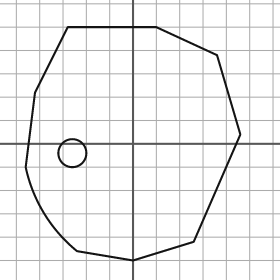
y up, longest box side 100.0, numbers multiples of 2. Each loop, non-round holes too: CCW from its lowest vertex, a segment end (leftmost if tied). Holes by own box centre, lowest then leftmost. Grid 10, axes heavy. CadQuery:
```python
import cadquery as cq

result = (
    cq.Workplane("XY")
    .moveTo(0.0, -50.0)
    .lineTo(26.0, -42.0)
    .lineTo(46.0, 4.0)
    .lineTo(36.0, 38.0)
    .lineTo(10.0, 50.0)
    .lineTo(-28.0, 50.0)
    .lineTo(-42.0, 22.0)
    .lineTo(-46.0, -10.0)
    .threePointArc((-38.0, -30.0), (-24.0, -46.0))
    .close()
    .moveTo(-26.0, -4.0)
    .circle(6.0)
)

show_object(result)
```